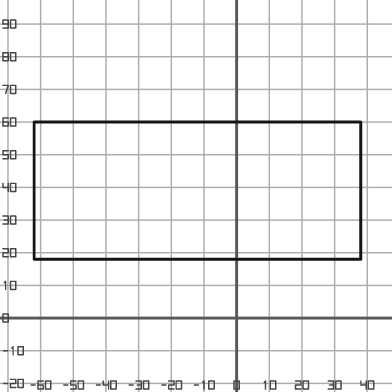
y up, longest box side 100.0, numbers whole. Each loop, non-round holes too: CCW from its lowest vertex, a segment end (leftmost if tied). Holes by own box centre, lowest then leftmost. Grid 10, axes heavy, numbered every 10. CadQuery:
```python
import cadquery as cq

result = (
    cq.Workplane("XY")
    .moveTo(-62.0, 18.0)
    .lineTo(38.0, 18.0)
    .lineTo(38.0, 60.0)
    .lineTo(-62.0, 60.0)
    .close()
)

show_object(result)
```